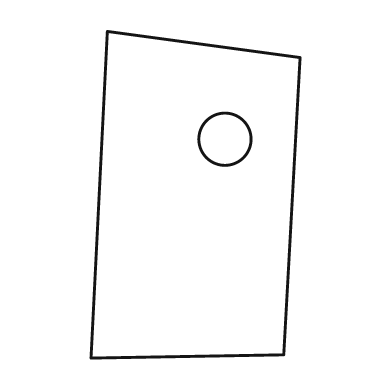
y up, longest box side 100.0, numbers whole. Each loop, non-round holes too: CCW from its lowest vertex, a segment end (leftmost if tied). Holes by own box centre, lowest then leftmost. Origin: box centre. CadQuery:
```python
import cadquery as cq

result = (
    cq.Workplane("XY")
    .moveTo(-32.0, -50.0)
    .lineTo(27.0, -49.0)
    .lineTo(32.0, 42.0)
    .lineTo(-27.0, 50.0)
    .close()
    .moveTo(9.0, 17.0)
    .circle(8.0)
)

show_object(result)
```